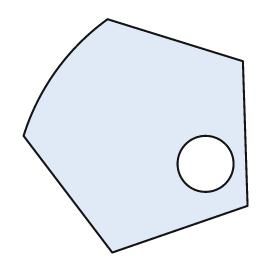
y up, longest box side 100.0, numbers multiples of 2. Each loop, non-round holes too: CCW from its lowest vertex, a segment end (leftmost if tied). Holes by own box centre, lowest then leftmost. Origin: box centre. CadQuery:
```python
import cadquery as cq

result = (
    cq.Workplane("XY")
    .moveTo(-10.0, -50.0)
    .lineTo(48.0, -30.0)
    .lineTo(46.0, 32.0)
    .lineTo(-12.0, 50.0)
    .threePointArc((-34.0, 28.0), (-48.0, 0.0))
    .close()
    .moveTo(30.0, -12.0)
    .circle(12.0)
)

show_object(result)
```